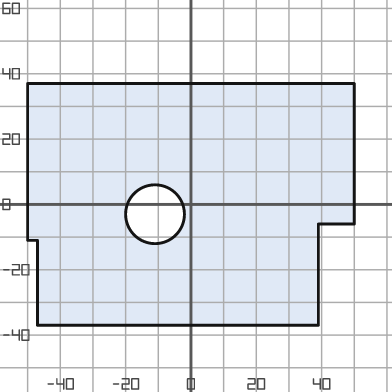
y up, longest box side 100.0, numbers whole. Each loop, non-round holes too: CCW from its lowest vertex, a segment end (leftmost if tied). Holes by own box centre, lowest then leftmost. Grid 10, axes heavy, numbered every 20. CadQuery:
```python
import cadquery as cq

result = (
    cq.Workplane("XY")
    .moveTo(-47.0, -37.0)
    .lineTo(39.0, -37.0)
    .lineTo(39.0, -6.0)
    .lineTo(50.0, -6.0)
    .lineTo(50.0, 37.0)
    .lineTo(-50.0, 37.0)
    .lineTo(-50.0, -11.0)
    .lineTo(-47.0, -11.0)
    .close()
    .moveTo(-11.0, -3.0)
    .circle(9.0)
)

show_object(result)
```